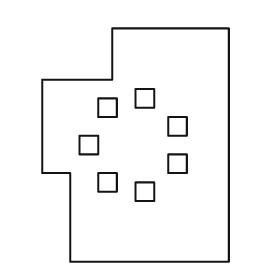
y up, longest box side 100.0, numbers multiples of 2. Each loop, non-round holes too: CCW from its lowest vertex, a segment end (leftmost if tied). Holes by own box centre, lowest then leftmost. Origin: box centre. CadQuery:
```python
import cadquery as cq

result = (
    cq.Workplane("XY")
    .moveTo(-28.0, -50.0)
    .lineTo(40.0, -50.0)
    .lineTo(40.0, 50.0)
    .lineTo(-10.0, 50.0)
    .lineTo(-10.0, 28.0)
    .lineTo(-40.0, 28.0)
    .lineTo(-40.0, -12.0)
    .lineTo(-28.0, -12.0)
    .close()
    .moveTo(0.0, -24.0)
    .lineTo(8.0, -24.0)
    .lineTo(8.0, -16.0)
    .lineTo(0.0, -16.0)
    .close()
    .moveTo(-16.0, -20.0)
    .lineTo(-8.0, -20.0)
    .lineTo(-8.0, -12.0)
    .lineTo(-16.0, -12.0)
    .close()
    .moveTo(14.0, -12.0)
    .lineTo(22.0, -12.0)
    .lineTo(22.0, -4.0)
    .lineTo(14.0, -4.0)
    .close()
    .moveTo(-24.0, -4.0)
    .lineTo(-16.0, -4.0)
    .lineTo(-16.0, 4.0)
    .lineTo(-24.0, 4.0)
    .close()
    .moveTo(14.0, 4.0)
    .lineTo(22.0, 4.0)
    .lineTo(22.0, 12.0)
    .lineTo(14.0, 12.0)
    .close()
    .moveTo(-16.0, 12.0)
    .lineTo(-8.0, 12.0)
    .lineTo(-8.0, 20.0)
    .lineTo(-16.0, 20.0)
    .close()
    .moveTo(0.0, 16.0)
    .lineTo(8.0, 16.0)
    .lineTo(8.0, 24.0)
    .lineTo(0.0, 24.0)
    .close()
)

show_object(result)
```